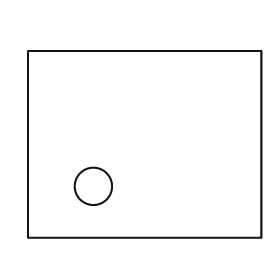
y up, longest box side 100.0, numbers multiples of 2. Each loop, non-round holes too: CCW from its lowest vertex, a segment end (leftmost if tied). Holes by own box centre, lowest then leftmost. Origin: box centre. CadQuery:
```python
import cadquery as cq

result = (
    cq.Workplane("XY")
    .moveTo(-50.0, -40.0)
    .lineTo(50.0, -40.0)
    .lineTo(50.0, 40.0)
    .lineTo(-50.0, 40.0)
    .close()
    .moveTo(-22.0, -18.0)
    .circle(8.0)
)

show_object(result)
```